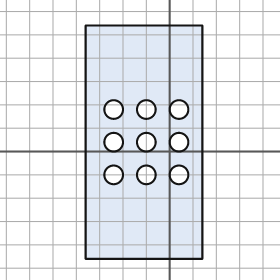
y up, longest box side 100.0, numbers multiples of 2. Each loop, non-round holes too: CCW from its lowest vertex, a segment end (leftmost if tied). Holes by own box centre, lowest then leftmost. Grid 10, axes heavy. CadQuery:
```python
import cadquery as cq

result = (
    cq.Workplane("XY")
    .moveTo(-36.0, -46.0)
    .lineTo(14.0, -46.0)
    .lineTo(14.0, 54.0)
    .lineTo(-36.0, 54.0)
    .close()
    .moveTo(-24.0, -10.0)
    .circle(4.0)
    .moveTo(-10.0, -10.0)
    .circle(4.0)
    .moveTo(4.0, -10.0)
    .circle(4.0)
    .moveTo(-24.0, 4.0)
    .circle(4.0)
    .moveTo(-10.0, 4.0)
    .circle(4.0)
    .moveTo(4.0, 4.0)
    .circle(4.0)
    .moveTo(-24.0, 18.0)
    .circle(4.0)
    .moveTo(-10.0, 18.0)
    .circle(4.0)
    .moveTo(4.0, 18.0)
    .circle(4.0)
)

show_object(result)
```